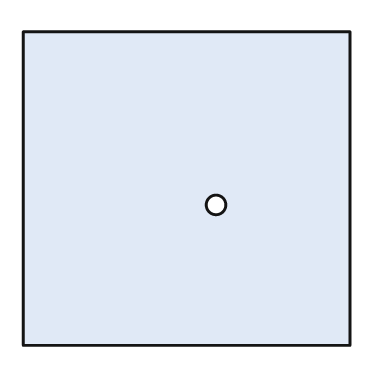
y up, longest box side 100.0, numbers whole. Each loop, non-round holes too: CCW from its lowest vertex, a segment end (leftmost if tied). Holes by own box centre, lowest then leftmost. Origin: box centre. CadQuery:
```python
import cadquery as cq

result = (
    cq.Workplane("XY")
    .moveTo(-50.0, -48.0)
    .lineTo(50.0, -48.0)
    .lineTo(50.0, 48.0)
    .lineTo(-50.0, 48.0)
    .close()
    .moveTo(9.0, -5.0)
    .circle(3.0)
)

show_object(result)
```